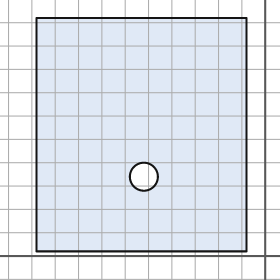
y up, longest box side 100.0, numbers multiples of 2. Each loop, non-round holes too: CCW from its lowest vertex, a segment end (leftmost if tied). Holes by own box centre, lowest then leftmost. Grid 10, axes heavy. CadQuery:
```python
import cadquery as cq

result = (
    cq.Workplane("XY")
    .moveTo(-98.0, 2.0)
    .lineTo(-8.0, 2.0)
    .lineTo(-8.0, 102.0)
    .lineTo(-98.0, 102.0)
    .close()
    .moveTo(-52.0, 34.0)
    .circle(6.0)
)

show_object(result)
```